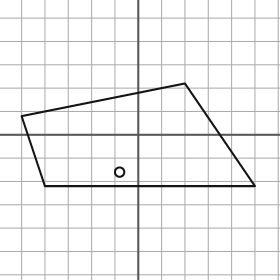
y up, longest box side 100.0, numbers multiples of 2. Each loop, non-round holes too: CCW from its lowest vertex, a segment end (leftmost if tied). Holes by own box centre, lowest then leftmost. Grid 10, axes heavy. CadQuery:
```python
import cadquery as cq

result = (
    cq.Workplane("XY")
    .moveTo(-40.0, -22.0)
    .lineTo(50.0, -22.0)
    .lineTo(20.0, 22.0)
    .lineTo(-50.0, 8.0)
    .close()
    .moveTo(-8.0, -16.0)
    .circle(2.0)
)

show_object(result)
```